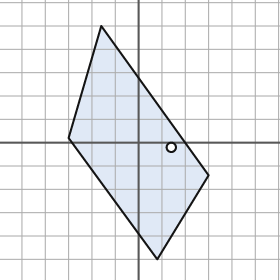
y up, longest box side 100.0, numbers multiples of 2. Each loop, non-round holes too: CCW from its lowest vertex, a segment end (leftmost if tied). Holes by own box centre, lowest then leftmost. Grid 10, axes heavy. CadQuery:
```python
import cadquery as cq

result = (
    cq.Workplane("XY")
    .moveTo(8.0, -50.0)
    .lineTo(30.0, -14.0)
    .lineTo(-16.0, 50.0)
    .lineTo(-30.0, 2.0)
    .close()
    .moveTo(14.0, -2.0)
    .circle(2.0)
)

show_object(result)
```